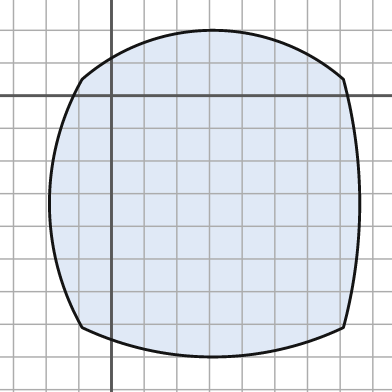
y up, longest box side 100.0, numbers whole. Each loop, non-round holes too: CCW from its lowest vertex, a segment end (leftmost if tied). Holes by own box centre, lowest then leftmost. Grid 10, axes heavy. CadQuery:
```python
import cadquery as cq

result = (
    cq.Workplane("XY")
    .moveTo(-9.0, -71.0)
    .threePointArc((31.0, -80.0), (71.0, -71.0))
    .threePointArc((76.0, -33.0), (71.0, 5.0))
    .threePointArc((31.0, 20.0), (-9.0, 5.0))
    .threePointArc((-19.0, -33.0), (-9.0, -71.0))
    .close()
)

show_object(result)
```